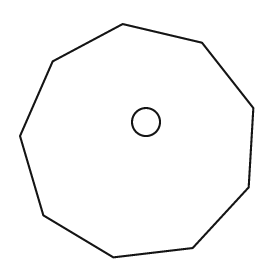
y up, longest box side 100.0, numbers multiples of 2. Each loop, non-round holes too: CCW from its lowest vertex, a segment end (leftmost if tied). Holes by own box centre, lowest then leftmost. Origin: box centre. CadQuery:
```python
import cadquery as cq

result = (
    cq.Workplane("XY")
    .moveTo(-10.0, -50.0)
    .lineTo(24.0, -46.0)
    .lineTo(48.0, -20.0)
    .lineTo(50.0, 14.0)
    .lineTo(28.0, 42.0)
    .lineTo(-6.0, 50.0)
    .lineTo(-36.0, 34.0)
    .lineTo(-50.0, 2.0)
    .lineTo(-40.0, -32.0)
    .close()
    .moveTo(4.0, 8.0)
    .circle(6.0)
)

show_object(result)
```